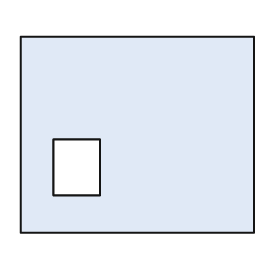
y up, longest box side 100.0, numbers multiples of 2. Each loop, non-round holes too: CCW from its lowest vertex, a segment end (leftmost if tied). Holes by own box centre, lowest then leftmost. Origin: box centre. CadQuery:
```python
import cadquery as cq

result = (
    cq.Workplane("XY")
    .moveTo(-50.0, -42.0)
    .lineTo(50.0, -42.0)
    .lineTo(50.0, 42.0)
    .lineTo(-50.0, 42.0)
    .close()
    .moveTo(-36.0, -26.0)
    .lineTo(-16.0, -26.0)
    .lineTo(-16.0, -2.0)
    .lineTo(-36.0, -2.0)
    .close()
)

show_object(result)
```